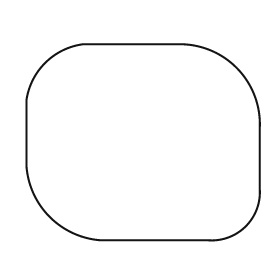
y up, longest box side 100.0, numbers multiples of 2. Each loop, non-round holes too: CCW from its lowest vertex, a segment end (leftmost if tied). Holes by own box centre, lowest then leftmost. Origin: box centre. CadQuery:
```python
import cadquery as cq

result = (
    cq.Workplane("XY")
    .moveTo(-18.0, -42.0)
    .lineTo(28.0, -42.0)
    .threePointArc((44.0, -36.0), (50.0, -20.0))
    .lineTo(50.0, 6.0)
    .threePointArc((40.0, 32.0), (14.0, 42.0))
    .lineTo(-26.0, 42.0)
    .threePointArc((-42.0, 34.0), (-50.0, 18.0))
    .lineTo(-50.0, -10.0)
    .threePointArc((-40.0, -32.0), (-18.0, -42.0))
    .close()
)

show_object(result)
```